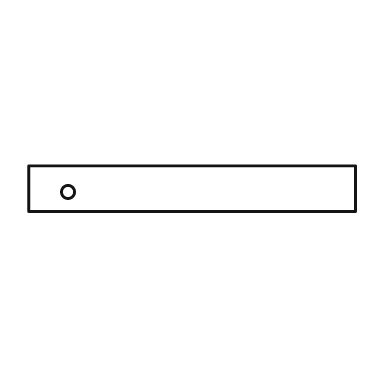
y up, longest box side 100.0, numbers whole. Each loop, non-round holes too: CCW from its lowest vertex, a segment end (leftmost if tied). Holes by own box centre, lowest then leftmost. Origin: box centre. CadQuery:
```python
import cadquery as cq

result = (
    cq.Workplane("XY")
    .moveTo(-50.0, -7.0)
    .lineTo(50.0, -7.0)
    .lineTo(50.0, 7.0)
    .lineTo(-50.0, 7.0)
    .close()
    .moveTo(-38.0, -1.0)
    .circle(2.0)
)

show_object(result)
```